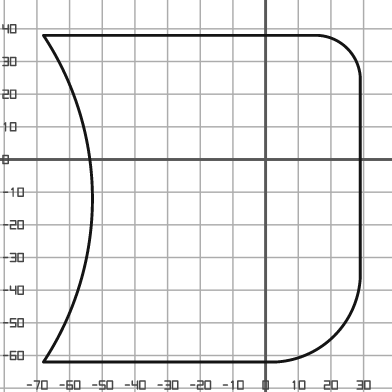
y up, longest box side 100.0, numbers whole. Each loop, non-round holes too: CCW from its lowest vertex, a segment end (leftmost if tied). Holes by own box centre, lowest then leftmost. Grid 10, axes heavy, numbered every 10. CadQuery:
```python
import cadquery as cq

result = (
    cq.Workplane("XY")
    .moveTo(-68.0, -62.0)
    .lineTo(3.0, -62.0)
    .threePointArc((21.0, -54.0), (29.0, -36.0))
    .lineTo(29.0, 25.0)
    .threePointArc((25.0, 34.0), (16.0, 38.0))
    .lineTo(-68.0, 38.0)
    .threePointArc((-53.0, -12.0), (-68.0, -62.0))
    .close()
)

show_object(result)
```